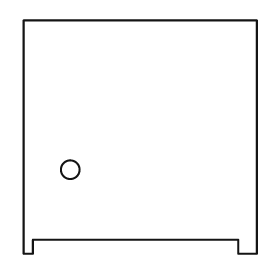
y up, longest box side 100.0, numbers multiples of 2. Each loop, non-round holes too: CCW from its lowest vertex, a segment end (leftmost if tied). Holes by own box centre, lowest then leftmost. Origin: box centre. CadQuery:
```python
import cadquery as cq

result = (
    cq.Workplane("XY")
    .moveTo(-50.0, -50.0)
    .lineTo(-46.0, -50.0)
    .lineTo(-46.0, -44.0)
    .lineTo(42.0, -44.0)
    .lineTo(42.0, -50.0)
    .lineTo(50.0, -50.0)
    .lineTo(50.0, 50.0)
    .lineTo(-50.0, 50.0)
    .close()
    .moveTo(-30.0, -14.0)
    .circle(4.0)
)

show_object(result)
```